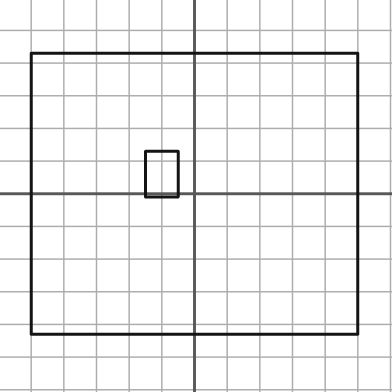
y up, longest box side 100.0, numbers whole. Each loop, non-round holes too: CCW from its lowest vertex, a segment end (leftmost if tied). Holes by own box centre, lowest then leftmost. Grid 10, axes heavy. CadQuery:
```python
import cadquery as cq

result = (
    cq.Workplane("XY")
    .moveTo(-50.0, -43.0)
    .lineTo(50.0, -43.0)
    .lineTo(50.0, 43.0)
    .lineTo(-50.0, 43.0)
    .close()
    .moveTo(-15.0, -1.0)
    .lineTo(-5.0, -1.0)
    .lineTo(-5.0, 13.0)
    .lineTo(-15.0, 13.0)
    .close()
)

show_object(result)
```